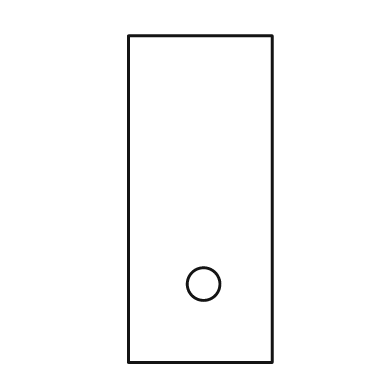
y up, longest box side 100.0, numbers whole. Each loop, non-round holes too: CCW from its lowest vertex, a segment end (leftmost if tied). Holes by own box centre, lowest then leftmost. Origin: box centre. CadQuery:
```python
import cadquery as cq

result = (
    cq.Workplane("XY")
    .moveTo(-22.0, -50.0)
    .lineTo(22.0, -50.0)
    .lineTo(22.0, 50.0)
    .lineTo(-22.0, 50.0)
    .close()
    .moveTo(1.0, -26.0)
    .circle(5.0)
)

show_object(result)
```